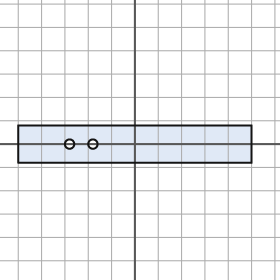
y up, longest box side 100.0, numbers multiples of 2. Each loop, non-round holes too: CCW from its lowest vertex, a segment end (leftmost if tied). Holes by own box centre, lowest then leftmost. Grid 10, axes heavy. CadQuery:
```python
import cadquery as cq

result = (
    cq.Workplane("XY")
    .moveTo(-50.0, -8.0)
    .lineTo(50.0, -8.0)
    .lineTo(50.0, 8.0)
    .lineTo(-50.0, 8.0)
    .close()
    .moveTo(-28.0, 0.0)
    .circle(2.0)
    .moveTo(-18.0, 0.0)
    .circle(2.0)
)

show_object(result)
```